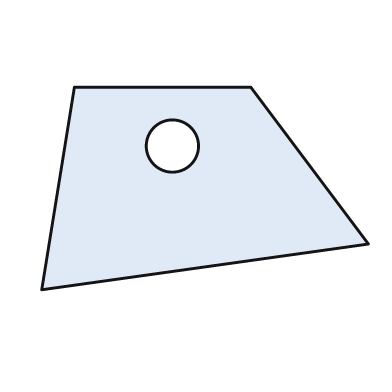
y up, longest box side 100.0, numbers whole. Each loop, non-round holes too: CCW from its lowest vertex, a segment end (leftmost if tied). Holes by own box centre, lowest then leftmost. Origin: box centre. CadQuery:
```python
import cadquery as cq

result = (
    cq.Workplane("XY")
    .moveTo(-50.0, -31.0)
    .lineTo(50.0, -17.0)
    .lineTo(14.0, 31.0)
    .lineTo(-40.0, 31.0)
    .close()
    .moveTo(-10.0, 13.0)
    .circle(8.0)
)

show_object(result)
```